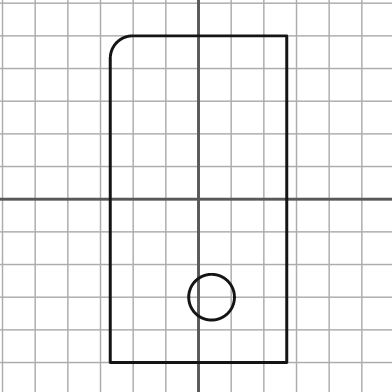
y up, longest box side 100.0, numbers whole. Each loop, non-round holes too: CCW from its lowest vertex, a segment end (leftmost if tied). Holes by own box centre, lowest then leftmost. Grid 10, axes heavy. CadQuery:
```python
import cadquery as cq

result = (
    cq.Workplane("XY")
    .moveTo(-27.0, -50.0)
    .lineTo(27.0, -50.0)
    .lineTo(27.0, 50.0)
    .lineTo(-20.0, 50.0)
    .threePointArc((-25.0, 48.0), (-27.0, 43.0))
    .close()
    .moveTo(4.0, -30.0)
    .circle(7.0)
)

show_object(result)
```